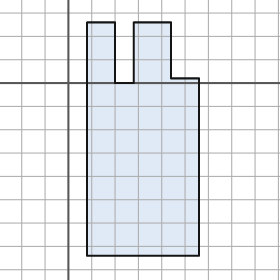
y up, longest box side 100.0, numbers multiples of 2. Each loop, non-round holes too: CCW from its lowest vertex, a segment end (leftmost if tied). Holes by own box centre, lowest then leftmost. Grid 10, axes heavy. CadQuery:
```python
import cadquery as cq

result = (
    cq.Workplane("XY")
    .moveTo(8.0, -74.0)
    .lineTo(56.0, -74.0)
    .lineTo(56.0, 2.0)
    .lineTo(44.0, 2.0)
    .lineTo(44.0, 26.0)
    .lineTo(28.0, 26.0)
    .lineTo(28.0, 0.0)
    .lineTo(20.0, 0.0)
    .lineTo(20.0, 26.0)
    .lineTo(8.0, 26.0)
    .close()
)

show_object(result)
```